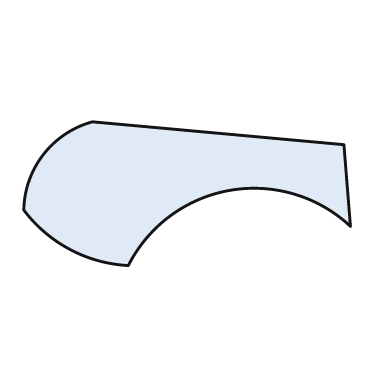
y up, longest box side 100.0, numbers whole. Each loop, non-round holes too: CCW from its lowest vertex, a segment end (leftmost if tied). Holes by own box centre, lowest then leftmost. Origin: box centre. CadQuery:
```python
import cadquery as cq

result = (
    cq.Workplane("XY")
    .moveTo(-18.0, -22.0)
    .threePointArc((13.0, 1.0), (50.0, -10.0))
    .lineTo(48.0, 15.0)
    .lineTo(-29.0, 22.0)
    .threePointArc((-44.0, 12.0), (-50.0, -5.0))
    .threePointArc((-36.0, -17.0), (-18.0, -22.0))
    .close()
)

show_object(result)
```